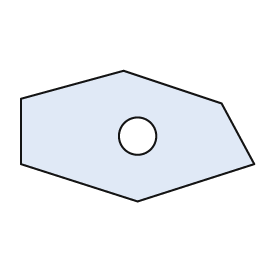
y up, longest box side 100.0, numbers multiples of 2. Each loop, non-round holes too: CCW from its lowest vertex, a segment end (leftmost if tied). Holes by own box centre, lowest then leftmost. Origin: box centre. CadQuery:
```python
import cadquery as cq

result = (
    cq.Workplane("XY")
    .moveTo(0.0, -28.0)
    .lineTo(50.0, -12.0)
    .lineTo(36.0, 14.0)
    .lineTo(-6.0, 28.0)
    .lineTo(-50.0, 16.0)
    .lineTo(-50.0, -12.0)
    .close()
    .moveTo(0.0, 0.0)
    .circle(8.0)
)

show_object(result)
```